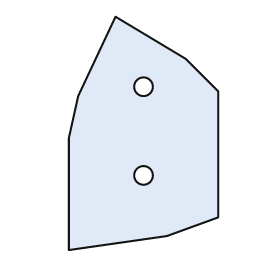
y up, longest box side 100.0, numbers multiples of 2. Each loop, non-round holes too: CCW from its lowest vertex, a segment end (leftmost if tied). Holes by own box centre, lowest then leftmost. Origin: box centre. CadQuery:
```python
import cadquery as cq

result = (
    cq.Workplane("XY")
    .moveTo(-32.0, -50.0)
    .lineTo(10.0, -44.0)
    .lineTo(32.0, -36.0)
    .lineTo(32.0, 18.0)
    .lineTo(18.0, 32.0)
    .lineTo(-12.0, 50.0)
    .lineTo(-28.0, 16.0)
    .lineTo(-32.0, -2.0)
    .close()
    .moveTo(0.0, -18.0)
    .circle(4.0)
    .moveTo(0.0, 20.0)
    .circle(4.0)
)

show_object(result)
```